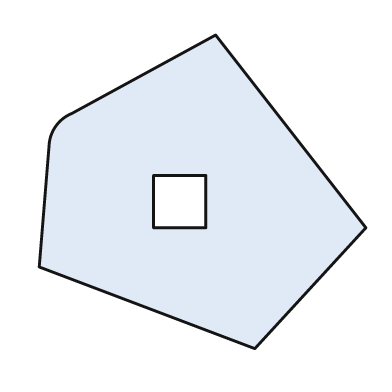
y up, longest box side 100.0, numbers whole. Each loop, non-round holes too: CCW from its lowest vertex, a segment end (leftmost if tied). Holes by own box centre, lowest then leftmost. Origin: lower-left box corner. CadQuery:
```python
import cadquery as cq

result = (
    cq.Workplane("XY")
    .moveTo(66.0, 0.0)
    .lineTo(100.0, 37.0)
    .lineTo(54.0, 96.0)
    .lineTo(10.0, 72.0)
    .threePointArc((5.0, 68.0), (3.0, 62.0))
    .lineTo(0.0, 25.0)
    .close()
    .moveTo(35.0, 37.0)
    .lineTo(51.0, 37.0)
    .lineTo(51.0, 53.0)
    .lineTo(35.0, 53.0)
    .close()
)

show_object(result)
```